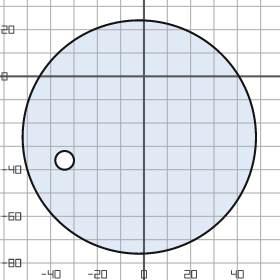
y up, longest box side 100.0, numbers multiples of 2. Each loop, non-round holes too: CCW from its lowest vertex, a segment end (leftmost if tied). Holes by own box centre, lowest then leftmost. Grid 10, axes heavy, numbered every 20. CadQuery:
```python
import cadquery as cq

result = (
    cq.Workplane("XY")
    .moveTo(-2.0, -26.0)
    .circle(50.0)
    .moveTo(-34.0, -36.0)
    .circle(4.0)
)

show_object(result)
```